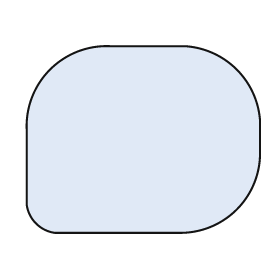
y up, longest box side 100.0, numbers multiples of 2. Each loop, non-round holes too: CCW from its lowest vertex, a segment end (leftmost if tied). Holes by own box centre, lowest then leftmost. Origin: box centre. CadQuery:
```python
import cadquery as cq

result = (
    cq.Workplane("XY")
    .moveTo(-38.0, -40.0)
    .lineTo(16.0, -40.0)
    .threePointArc((40.0, -30.0), (50.0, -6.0))
    .lineTo(50.0, 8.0)
    .threePointArc((40.0, 30.0), (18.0, 40.0))
    .lineTo(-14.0, 40.0)
    .threePointArc((-40.0, 30.0), (-50.0, 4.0))
    .lineTo(-50.0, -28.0)
    .threePointArc((-46.0, -36.0), (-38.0, -40.0))
    .close()
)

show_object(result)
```